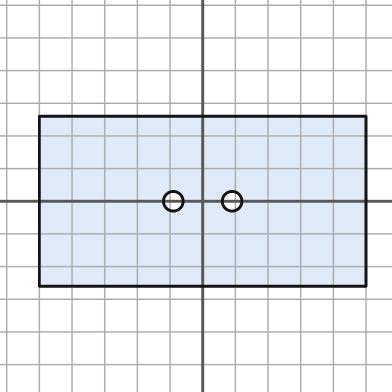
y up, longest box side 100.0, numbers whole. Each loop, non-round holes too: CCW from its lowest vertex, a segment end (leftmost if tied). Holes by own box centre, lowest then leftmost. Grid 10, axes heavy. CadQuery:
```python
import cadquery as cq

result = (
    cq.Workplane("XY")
    .moveTo(-50.0, -26.0)
    .lineTo(50.0, -26.0)
    .lineTo(50.0, 26.0)
    .lineTo(-50.0, 26.0)
    .close()
    .moveTo(-9.0, 0.0)
    .circle(3.0)
    .moveTo(9.0, 0.0)
    .circle(3.0)
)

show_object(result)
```